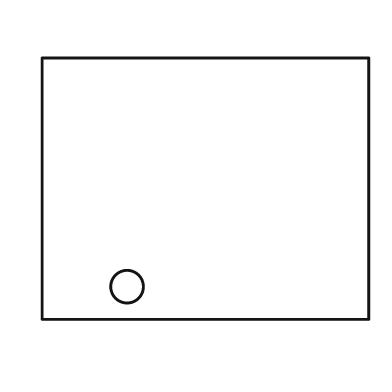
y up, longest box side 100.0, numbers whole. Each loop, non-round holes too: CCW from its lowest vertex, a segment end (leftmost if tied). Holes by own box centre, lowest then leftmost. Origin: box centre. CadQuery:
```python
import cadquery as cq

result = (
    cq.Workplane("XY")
    .moveTo(-50.0, -40.0)
    .lineTo(50.0, -40.0)
    .lineTo(50.0, 40.0)
    .lineTo(-50.0, 40.0)
    .close()
    .moveTo(-24.0, -30.0)
    .circle(5.0)
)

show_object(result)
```